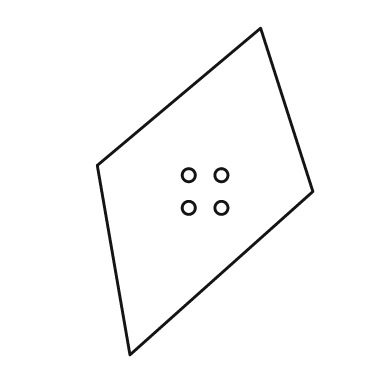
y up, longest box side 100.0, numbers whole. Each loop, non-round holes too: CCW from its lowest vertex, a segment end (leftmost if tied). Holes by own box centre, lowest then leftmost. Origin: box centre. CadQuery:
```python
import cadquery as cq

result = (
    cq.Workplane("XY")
    .moveTo(-23.0, -50.0)
    .lineTo(33.0, 0.0)
    .lineTo(17.0, 50.0)
    .lineTo(-33.0, 8.0)
    .close()
    .moveTo(-5.0, -5.0)
    .circle(2.0)
    .moveTo(5.0, -5.0)
    .circle(2.0)
    .moveTo(-5.0, 5.0)
    .circle(2.0)
    .moveTo(5.0, 5.0)
    .circle(2.0)
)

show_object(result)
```